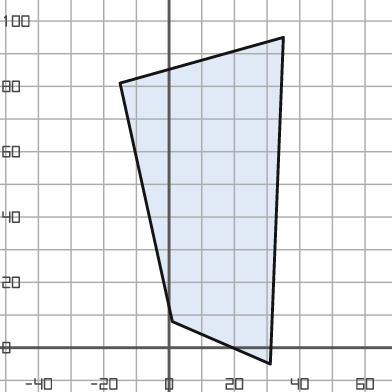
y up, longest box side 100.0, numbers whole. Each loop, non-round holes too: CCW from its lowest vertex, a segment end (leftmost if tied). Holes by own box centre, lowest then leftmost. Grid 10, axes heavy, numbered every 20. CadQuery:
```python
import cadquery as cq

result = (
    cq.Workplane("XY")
    .moveTo(31.0, -5.0)
    .lineTo(35.0, 95.0)
    .lineTo(-15.0, 81.0)
    .lineTo(1.0, 8.0)
    .close()
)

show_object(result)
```